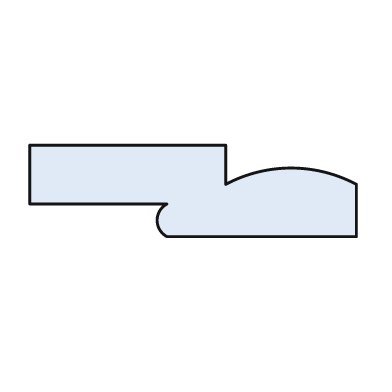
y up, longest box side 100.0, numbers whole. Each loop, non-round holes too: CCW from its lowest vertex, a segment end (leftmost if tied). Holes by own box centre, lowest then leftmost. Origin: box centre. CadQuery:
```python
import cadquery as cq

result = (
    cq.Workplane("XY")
    .moveTo(-8.0, -14.0)
    .lineTo(50.0, -14.0)
    .lineTo(50.0, 2.0)
    .threePointArc((30.0, 7.0), (10.0, 2.0))
    .lineTo(10.0, 14.0)
    .lineTo(-50.0, 14.0)
    .lineTo(-50.0, -4.0)
    .lineTo(-8.0, -4.0)
    .threePointArc((-11.0, -9.0), (-8.0, -14.0))
    .close()
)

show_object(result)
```